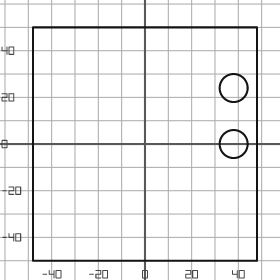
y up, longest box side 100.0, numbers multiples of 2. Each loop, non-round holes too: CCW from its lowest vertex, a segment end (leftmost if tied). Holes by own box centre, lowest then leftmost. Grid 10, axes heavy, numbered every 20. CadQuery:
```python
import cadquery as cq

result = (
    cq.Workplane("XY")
    .moveTo(-48.0, -50.0)
    .lineTo(48.0, -50.0)
    .lineTo(48.0, 50.0)
    .lineTo(-48.0, 50.0)
    .close()
    .moveTo(38.0, 0.0)
    .circle(6.0)
    .moveTo(38.0, 24.0)
    .circle(6.0)
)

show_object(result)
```